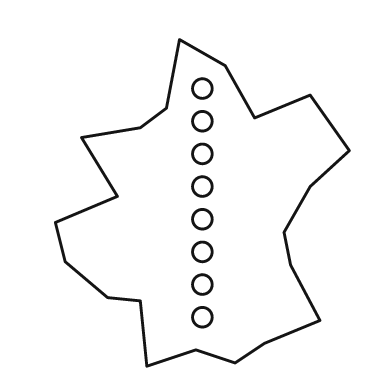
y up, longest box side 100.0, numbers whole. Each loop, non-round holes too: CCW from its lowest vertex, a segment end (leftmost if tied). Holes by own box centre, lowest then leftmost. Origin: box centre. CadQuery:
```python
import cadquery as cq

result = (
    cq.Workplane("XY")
    .moveTo(-17.0, -50.0)
    .lineTo(-2.0, -45.0)
    .lineTo(10.0, -49.0)
    .lineTo(19.0, -43.0)
    .lineTo(36.0, -36.0)
    .lineTo(27.0, -19.0)
    .lineTo(25.0, -9.0)
    .lineTo(33.0, 5.0)
    .lineTo(45.0, 16.0)
    .lineTo(33.0, 33.0)
    .lineTo(16.0, 26.0)
    .lineTo(7.0, 42.0)
    .lineTo(-7.0, 50.0)
    .lineTo(-11.0, 29.0)
    .lineTo(-19.0, 23.0)
    .lineTo(-37.0, 20.0)
    .lineTo(-26.0, 2.0)
    .lineTo(-45.0, -6.0)
    .lineTo(-42.0, -18.0)
    .lineTo(-29.0, -29.0)
    .lineTo(-19.0, -30.0)
    .close()
    .moveTo(0.0, -35.0)
    .circle(3.0)
    .moveTo(0.0, -25.0)
    .circle(3.0)
    .moveTo(0.0, -15.0)
    .circle(3.0)
    .moveTo(0.0, -5.0)
    .circle(3.0)
    .moveTo(0.0, 5.0)
    .circle(3.0)
    .moveTo(0.0, 15.0)
    .circle(3.0)
    .moveTo(0.0, 25.0)
    .circle(3.0)
    .moveTo(0.0, 35.0)
    .circle(3.0)
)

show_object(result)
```